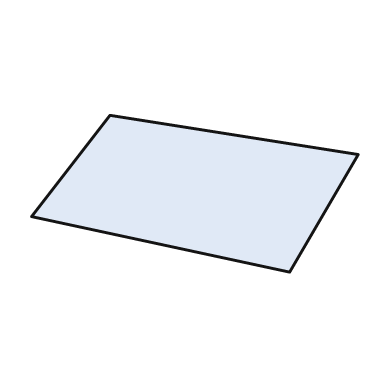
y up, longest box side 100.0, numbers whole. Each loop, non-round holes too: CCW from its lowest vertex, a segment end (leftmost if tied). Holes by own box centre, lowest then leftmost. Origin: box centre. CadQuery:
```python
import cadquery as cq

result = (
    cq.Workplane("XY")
    .moveTo(29.0, -24.0)
    .lineTo(50.0, 12.0)
    .lineTo(-26.0, 24.0)
    .lineTo(-50.0, -7.0)
    .close()
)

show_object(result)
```